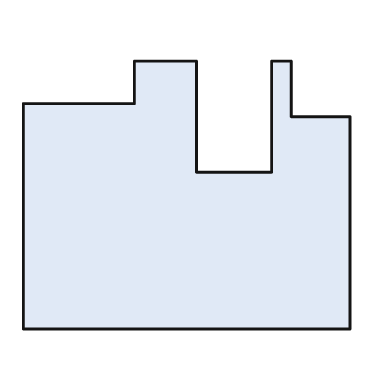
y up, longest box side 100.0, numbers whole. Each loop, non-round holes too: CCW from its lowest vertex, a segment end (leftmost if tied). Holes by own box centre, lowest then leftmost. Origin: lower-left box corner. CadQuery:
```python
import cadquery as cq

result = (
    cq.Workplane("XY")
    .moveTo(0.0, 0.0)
    .lineTo(100.0, 0.0)
    .lineTo(100.0, 65.0)
    .lineTo(82.0, 65.0)
    .lineTo(82.0, 82.0)
    .lineTo(76.0, 82.0)
    .lineTo(76.0, 48.0)
    .lineTo(53.0, 48.0)
    .lineTo(53.0, 82.0)
    .lineTo(34.0, 82.0)
    .lineTo(34.0, 69.0)
    .lineTo(0.0, 69.0)
    .close()
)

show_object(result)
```